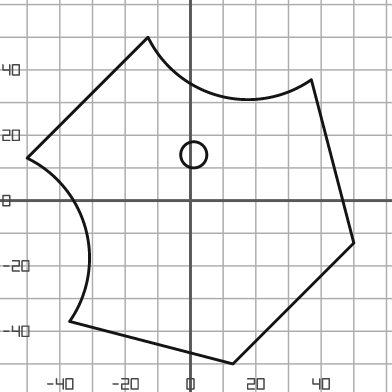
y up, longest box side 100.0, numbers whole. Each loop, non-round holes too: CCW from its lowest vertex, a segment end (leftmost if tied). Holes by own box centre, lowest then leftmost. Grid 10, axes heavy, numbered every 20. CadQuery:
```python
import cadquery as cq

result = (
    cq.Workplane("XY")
    .moveTo(13.0, -50.0)
    .lineTo(50.0, -13.0)
    .lineTo(37.0, 37.0)
    .threePointArc((9.0, 32.0), (-13.0, 50.0))
    .lineTo(-50.0, 13.0)
    .threePointArc((-32.0, -9.0), (-37.0, -37.0))
    .close()
    .moveTo(1.0, 14.0)
    .circle(4.0)
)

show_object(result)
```